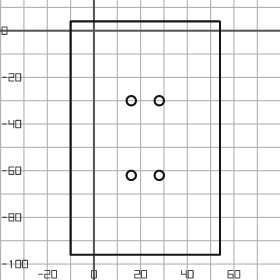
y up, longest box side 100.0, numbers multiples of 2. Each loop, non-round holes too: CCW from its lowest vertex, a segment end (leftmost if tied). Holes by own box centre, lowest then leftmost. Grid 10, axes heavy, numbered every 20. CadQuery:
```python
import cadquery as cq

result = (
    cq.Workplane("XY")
    .moveTo(-10.0, -96.0)
    .lineTo(54.0, -96.0)
    .lineTo(54.0, 4.0)
    .lineTo(-10.0, 4.0)
    .close()
    .moveTo(16.0, -62.0)
    .circle(2.0)
    .moveTo(28.0, -62.0)
    .circle(2.0)
    .moveTo(16.0, -30.0)
    .circle(2.0)
    .moveTo(28.0, -30.0)
    .circle(2.0)
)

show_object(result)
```